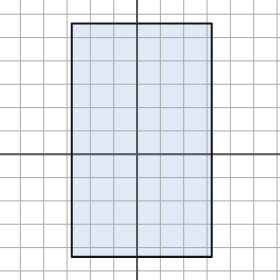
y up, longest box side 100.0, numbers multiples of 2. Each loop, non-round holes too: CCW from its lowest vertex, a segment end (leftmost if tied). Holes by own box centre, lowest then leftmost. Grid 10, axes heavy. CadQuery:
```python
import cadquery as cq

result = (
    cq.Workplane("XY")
    .moveTo(-28.0, -44.0)
    .lineTo(32.0, -44.0)
    .lineTo(32.0, 56.0)
    .lineTo(-28.0, 56.0)
    .close()
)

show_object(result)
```